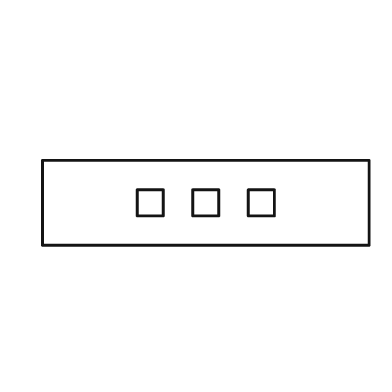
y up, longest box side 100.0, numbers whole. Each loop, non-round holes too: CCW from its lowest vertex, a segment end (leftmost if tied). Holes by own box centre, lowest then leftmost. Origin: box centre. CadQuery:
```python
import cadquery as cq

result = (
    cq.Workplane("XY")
    .moveTo(-50.0, -13.0)
    .lineTo(50.0, -13.0)
    .lineTo(50.0, 13.0)
    .lineTo(-50.0, 13.0)
    .close()
    .moveTo(-21.0, -4.0)
    .lineTo(-13.0, -4.0)
    .lineTo(-13.0, 4.0)
    .lineTo(-21.0, 4.0)
    .close()
    .moveTo(-4.0, -4.0)
    .lineTo(4.0, -4.0)
    .lineTo(4.0, 4.0)
    .lineTo(-4.0, 4.0)
    .close()
    .moveTo(13.0, -4.0)
    .lineTo(21.0, -4.0)
    .lineTo(21.0, 4.0)
    .lineTo(13.0, 4.0)
    .close()
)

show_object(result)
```